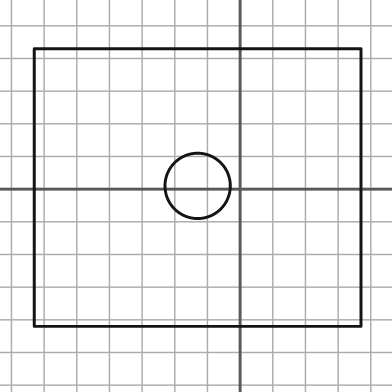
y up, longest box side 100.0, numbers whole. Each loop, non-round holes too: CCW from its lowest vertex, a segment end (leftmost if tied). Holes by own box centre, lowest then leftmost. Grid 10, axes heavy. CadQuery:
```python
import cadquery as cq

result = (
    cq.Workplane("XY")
    .moveTo(-63.0, -42.0)
    .lineTo(37.0, -42.0)
    .lineTo(37.0, 43.0)
    .lineTo(-63.0, 43.0)
    .close()
    .moveTo(-13.0, 1.0)
    .circle(10.0)
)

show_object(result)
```